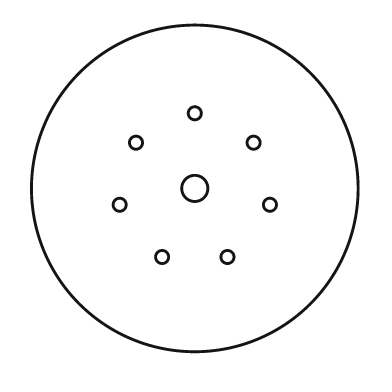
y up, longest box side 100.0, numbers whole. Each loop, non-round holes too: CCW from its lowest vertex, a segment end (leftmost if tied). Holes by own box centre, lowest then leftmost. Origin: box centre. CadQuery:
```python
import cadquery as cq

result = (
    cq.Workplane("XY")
    .moveTo(0.0, 0.0)
    .circle(50.0)
    .moveTo(-10.0, -21.0)
    .circle(2.0)
    .moveTo(10.0, -21.0)
    .circle(2.0)
    .moveTo(-23.0, -5.0)
    .circle(2.0)
    .moveTo(23.0, -5.0)
    .circle(2.0)
    .moveTo(0.0, 0.0)
    .circle(4.0)
    .moveTo(-18.0, 14.0)
    .circle(2.0)
    .moveTo(18.0, 14.0)
    .circle(2.0)
    .moveTo(0.0, 23.0)
    .circle(2.0)
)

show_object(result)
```